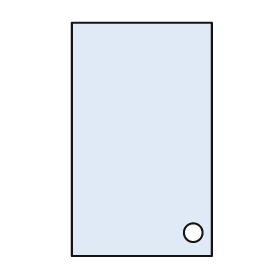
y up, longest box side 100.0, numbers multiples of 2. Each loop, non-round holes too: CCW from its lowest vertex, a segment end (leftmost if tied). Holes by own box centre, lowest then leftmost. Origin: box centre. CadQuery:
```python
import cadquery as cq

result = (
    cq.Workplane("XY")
    .moveTo(-30.0, -50.0)
    .lineTo(30.0, -50.0)
    .lineTo(30.0, 50.0)
    .lineTo(-30.0, 50.0)
    .close()
    .moveTo(22.0, -40.0)
    .circle(4.0)
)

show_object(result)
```